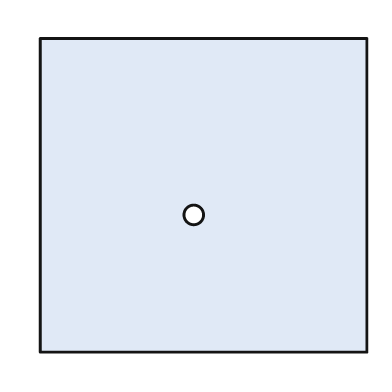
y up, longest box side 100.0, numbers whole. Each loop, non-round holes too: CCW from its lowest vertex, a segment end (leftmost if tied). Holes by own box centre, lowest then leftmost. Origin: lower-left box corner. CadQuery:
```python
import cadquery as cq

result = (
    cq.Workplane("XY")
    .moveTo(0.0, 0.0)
    .lineTo(100.0, 0.0)
    .lineTo(100.0, 96.0)
    .lineTo(0.0, 96.0)
    .close()
    .moveTo(47.0, 42.0)
    .circle(3.0)
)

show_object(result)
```